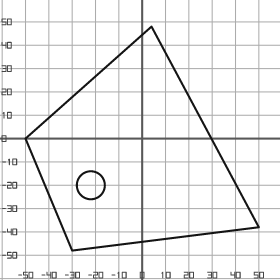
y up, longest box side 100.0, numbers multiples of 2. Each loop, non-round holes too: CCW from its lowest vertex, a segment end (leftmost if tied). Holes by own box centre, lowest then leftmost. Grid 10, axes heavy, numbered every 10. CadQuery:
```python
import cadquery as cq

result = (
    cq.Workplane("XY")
    .moveTo(-30.0, -48.0)
    .lineTo(50.0, -38.0)
    .lineTo(4.0, 48.0)
    .lineTo(-50.0, 0.0)
    .close()
    .moveTo(-22.0, -20.0)
    .circle(6.0)
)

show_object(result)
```